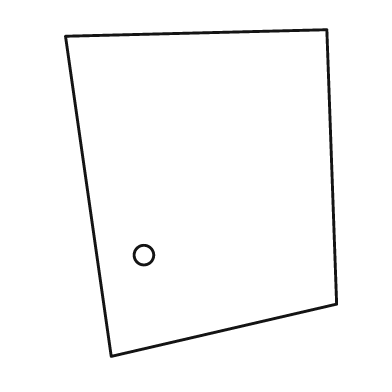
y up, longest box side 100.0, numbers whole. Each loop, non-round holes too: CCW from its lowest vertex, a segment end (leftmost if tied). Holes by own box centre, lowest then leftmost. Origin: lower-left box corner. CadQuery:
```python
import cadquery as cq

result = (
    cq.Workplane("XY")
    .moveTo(14.0, 0.0)
    .lineTo(83.0, 16.0)
    .lineTo(80.0, 100.0)
    .lineTo(0.0, 98.0)
    .close()
    .moveTo(24.0, 31.0)
    .circle(3.0)
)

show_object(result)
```